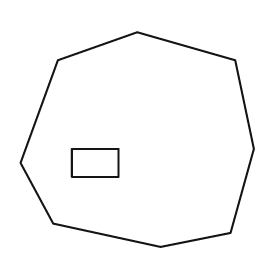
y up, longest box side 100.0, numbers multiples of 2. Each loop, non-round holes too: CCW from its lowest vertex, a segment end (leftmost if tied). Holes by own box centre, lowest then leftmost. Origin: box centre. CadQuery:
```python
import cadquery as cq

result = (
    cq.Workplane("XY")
    .moveTo(10.0, -46.0)
    .lineTo(40.0, -40.0)
    .lineTo(50.0, -4.0)
    .lineTo(42.0, 34.0)
    .lineTo(0.0, 46.0)
    .lineTo(-34.0, 34.0)
    .lineTo(-50.0, -10.0)
    .lineTo(-36.0, -36.0)
    .close()
    .moveTo(-28.0, -16.0)
    .lineTo(-8.0, -16.0)
    .lineTo(-8.0, -4.0)
    .lineTo(-28.0, -4.0)
    .close()
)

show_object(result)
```